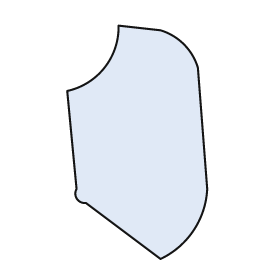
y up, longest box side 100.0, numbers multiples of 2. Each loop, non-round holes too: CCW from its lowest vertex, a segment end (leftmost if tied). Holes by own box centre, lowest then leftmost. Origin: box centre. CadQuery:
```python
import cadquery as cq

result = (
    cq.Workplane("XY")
    .moveTo(10.0, -50.0)
    .threePointArc((24.0, -38.0), (30.0, -20.0))
    .lineTo(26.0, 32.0)
    .threePointArc((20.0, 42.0), (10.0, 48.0))
    .lineTo(-8.0, 50.0)
    .threePointArc((-14.0, 32.0), (-30.0, 22.0))
    .lineTo(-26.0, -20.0)
    .threePointArc((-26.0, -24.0), (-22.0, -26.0))
    .close()
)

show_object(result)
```